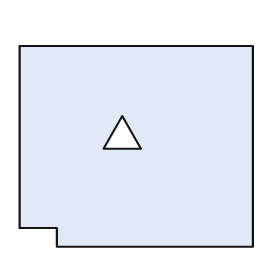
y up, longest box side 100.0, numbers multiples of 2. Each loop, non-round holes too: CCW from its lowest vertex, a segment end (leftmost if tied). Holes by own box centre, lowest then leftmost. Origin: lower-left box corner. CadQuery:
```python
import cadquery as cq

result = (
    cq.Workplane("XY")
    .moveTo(16.0, 0.0)
    .lineTo(100.0, 0.0)
    .lineTo(100.0, 86.0)
    .lineTo(0.0, 86.0)
    .lineTo(0.0, 8.0)
    .lineTo(16.0, 8.0)
    .close()
    .moveTo(36.0, 42.0)
    .lineTo(52.0, 42.0)
    .lineTo(44.0, 56.0)
    .close()
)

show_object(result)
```